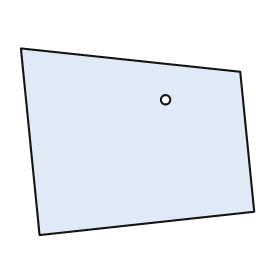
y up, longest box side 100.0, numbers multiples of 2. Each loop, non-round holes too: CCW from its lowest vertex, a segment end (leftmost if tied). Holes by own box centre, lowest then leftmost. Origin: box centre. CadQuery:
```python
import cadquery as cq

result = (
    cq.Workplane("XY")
    .moveTo(-42.0, -40.0)
    .lineTo(50.0, -30.0)
    .lineTo(44.0, 30.0)
    .lineTo(-50.0, 40.0)
    .close()
    .moveTo(12.0, 18.0)
    .circle(2.0)
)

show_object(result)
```